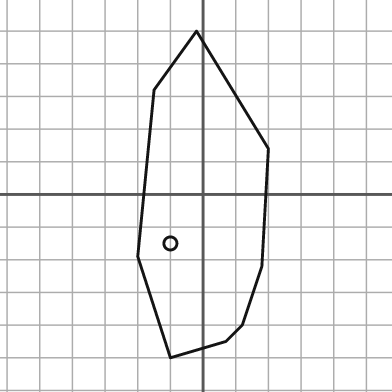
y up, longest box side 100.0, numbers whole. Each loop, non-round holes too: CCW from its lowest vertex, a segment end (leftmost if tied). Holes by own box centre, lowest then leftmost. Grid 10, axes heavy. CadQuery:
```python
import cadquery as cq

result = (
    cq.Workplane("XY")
    .moveTo(-10.0, -50.0)
    .lineTo(7.0, -45.0)
    .lineTo(12.0, -40.0)
    .lineTo(18.0, -22.0)
    .lineTo(20.0, 14.0)
    .lineTo(-2.0, 50.0)
    .lineTo(-15.0, 32.0)
    .lineTo(-20.0, -19.0)
    .close()
    .moveTo(-10.0, -15.0)
    .circle(2.0)
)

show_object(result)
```